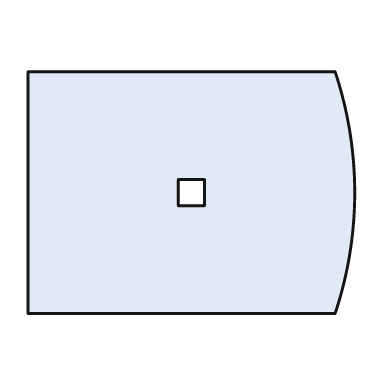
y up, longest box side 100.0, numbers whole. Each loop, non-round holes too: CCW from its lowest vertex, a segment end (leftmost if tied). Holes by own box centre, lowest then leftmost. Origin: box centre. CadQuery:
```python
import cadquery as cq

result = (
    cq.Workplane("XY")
    .moveTo(-50.0, -37.0)
    .lineTo(44.0, -37.0)
    .threePointArc((50.0, 0.0), (44.0, 37.0))
    .lineTo(-50.0, 37.0)
    .close()
    .moveTo(-4.0, -4.0)
    .lineTo(4.0, -4.0)
    .lineTo(4.0, 4.0)
    .lineTo(-4.0, 4.0)
    .close()
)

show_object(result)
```